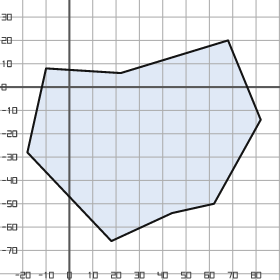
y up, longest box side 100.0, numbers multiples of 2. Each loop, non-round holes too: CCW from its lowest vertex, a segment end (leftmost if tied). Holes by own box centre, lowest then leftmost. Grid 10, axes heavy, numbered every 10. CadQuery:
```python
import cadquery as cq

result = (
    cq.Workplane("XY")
    .moveTo(18.0, -66.0)
    .lineTo(44.0, -54.0)
    .lineTo(62.0, -50.0)
    .lineTo(82.0, -14.0)
    .lineTo(68.0, 20.0)
    .lineTo(22.0, 6.0)
    .lineTo(-10.0, 8.0)
    .lineTo(-18.0, -28.0)
    .close()
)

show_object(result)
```